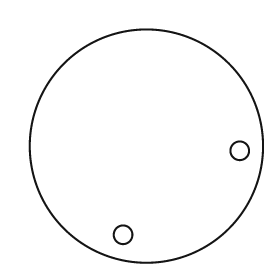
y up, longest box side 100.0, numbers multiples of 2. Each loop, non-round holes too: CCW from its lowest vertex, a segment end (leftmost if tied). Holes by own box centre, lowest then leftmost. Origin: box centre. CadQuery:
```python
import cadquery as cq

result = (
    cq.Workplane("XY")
    .moveTo(0.0, 0.0)
    .circle(50.0)
    .moveTo(-10.0, -38.0)
    .circle(4.0)
    .moveTo(40.0, -2.0)
    .circle(4.0)
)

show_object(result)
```